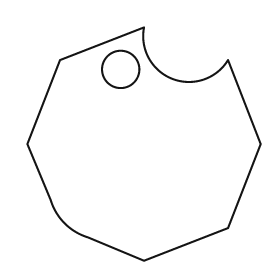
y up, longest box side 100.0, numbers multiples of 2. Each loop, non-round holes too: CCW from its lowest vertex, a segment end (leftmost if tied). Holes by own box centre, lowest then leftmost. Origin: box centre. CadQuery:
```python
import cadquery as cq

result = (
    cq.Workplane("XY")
    .moveTo(0.0, -50.0)
    .lineTo(36.0, -36.0)
    .lineTo(50.0, 0.0)
    .lineTo(36.0, 36.0)
    .threePointArc((12.0, 28.0), (0.0, 50.0))
    .lineTo(-36.0, 36.0)
    .lineTo(-50.0, 0.0)
    .lineTo(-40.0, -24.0)
    .threePointArc((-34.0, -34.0), (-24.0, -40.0))
    .close()
    .moveTo(-10.0, 32.0)
    .circle(8.0)
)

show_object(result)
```